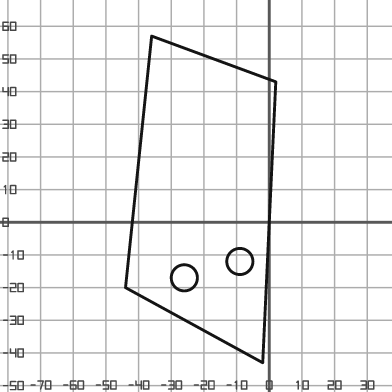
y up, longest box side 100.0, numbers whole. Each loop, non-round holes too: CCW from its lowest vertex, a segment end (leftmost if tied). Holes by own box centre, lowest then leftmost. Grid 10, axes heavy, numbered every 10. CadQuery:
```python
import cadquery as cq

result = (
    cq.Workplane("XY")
    .moveTo(-2.0, -43.0)
    .lineTo(2.0, 43.0)
    .lineTo(-36.0, 57.0)
    .lineTo(-44.0, -20.0)
    .close()
    .moveTo(-26.0, -17.0)
    .circle(4.0)
    .moveTo(-9.0, -12.0)
    .circle(4.0)
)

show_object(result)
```